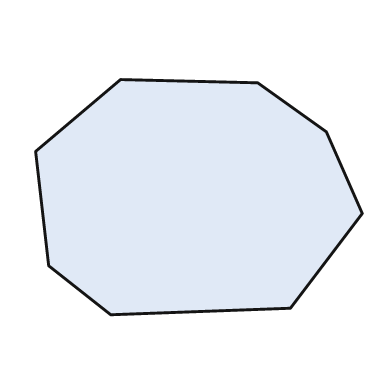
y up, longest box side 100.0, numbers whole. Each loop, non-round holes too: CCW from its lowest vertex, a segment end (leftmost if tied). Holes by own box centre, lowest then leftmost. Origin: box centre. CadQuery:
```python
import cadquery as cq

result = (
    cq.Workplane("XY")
    .moveTo(-27.0, -36.0)
    .lineTo(28.0, -34.0)
    .lineTo(50.0, -5.0)
    .lineTo(39.0, 20.0)
    .lineTo(18.0, 35.0)
    .lineTo(-24.0, 36.0)
    .lineTo(-50.0, 14.0)
    .lineTo(-46.0, -21.0)
    .close()
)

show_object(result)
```